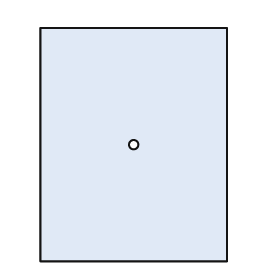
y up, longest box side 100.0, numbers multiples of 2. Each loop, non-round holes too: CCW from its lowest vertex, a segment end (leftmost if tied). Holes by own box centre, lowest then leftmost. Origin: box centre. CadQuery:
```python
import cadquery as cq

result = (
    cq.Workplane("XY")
    .moveTo(-40.0, -50.0)
    .lineTo(40.0, -50.0)
    .lineTo(40.0, 50.0)
    .lineTo(-40.0, 50.0)
    .close()
    .moveTo(0.0, 0.0)
    .circle(2.0)
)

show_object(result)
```